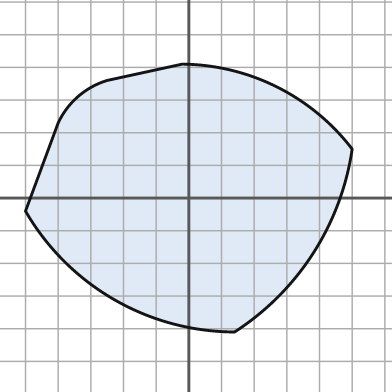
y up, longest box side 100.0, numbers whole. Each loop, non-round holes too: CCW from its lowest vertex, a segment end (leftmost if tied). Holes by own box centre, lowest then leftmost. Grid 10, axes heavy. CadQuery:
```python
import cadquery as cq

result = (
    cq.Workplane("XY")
    .moveTo(14.0, -41.0)
    .threePointArc((38.0, -17.0), (50.0, 15.0))
    .threePointArc((27.0, 34.0), (-2.0, 41.0))
    .lineTo(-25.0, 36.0)
    .threePointArc((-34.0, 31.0), (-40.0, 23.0))
    .lineTo(-50.0, -4.0)
    .threePointArc((-23.0, -31.0), (14.0, -41.0))
    .close()
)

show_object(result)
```